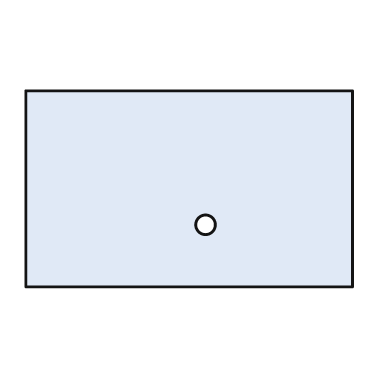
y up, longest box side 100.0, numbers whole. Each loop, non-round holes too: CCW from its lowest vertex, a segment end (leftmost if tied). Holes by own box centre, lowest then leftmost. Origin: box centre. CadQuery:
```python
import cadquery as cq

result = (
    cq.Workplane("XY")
    .moveTo(-50.0, -30.0)
    .lineTo(50.0, -30.0)
    .lineTo(50.0, 30.0)
    .lineTo(-50.0, 30.0)
    .close()
    .moveTo(5.0, -11.0)
    .circle(3.0)
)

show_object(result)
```